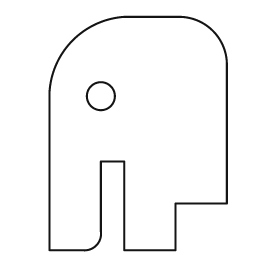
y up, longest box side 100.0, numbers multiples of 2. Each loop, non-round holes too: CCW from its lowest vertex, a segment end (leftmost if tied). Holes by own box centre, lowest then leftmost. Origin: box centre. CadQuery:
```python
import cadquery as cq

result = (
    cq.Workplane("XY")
    .moveTo(-38.0, -50.0)
    .lineTo(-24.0, -50.0)
    .threePointArc((-18.0, -48.0), (-16.0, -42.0))
    .lineTo(-16.0, -12.0)
    .lineTo(-6.0, -12.0)
    .lineTo(-6.0, -50.0)
    .lineTo(16.0, -50.0)
    .lineTo(16.0, -30.0)
    .lineTo(38.0, -30.0)
    .lineTo(38.0, 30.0)
    .threePointArc((32.0, 44.0), (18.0, 50.0))
    .lineTo(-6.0, 50.0)
    .threePointArc((-28.0, 40.0), (-38.0, 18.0))
    .close()
    .moveTo(-16.0, 16.0)
    .circle(6.0)
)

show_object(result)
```